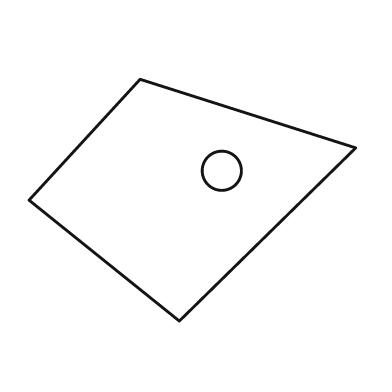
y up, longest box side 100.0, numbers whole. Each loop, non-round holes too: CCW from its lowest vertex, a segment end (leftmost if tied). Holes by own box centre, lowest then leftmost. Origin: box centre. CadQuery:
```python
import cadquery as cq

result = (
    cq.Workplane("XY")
    .moveTo(-4.0, -37.0)
    .lineTo(50.0, 16.0)
    .lineTo(-16.0, 37.0)
    .lineTo(-50.0, 0.0)
    .close()
    .moveTo(9.0, 9.0)
    .circle(6.0)
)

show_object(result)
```